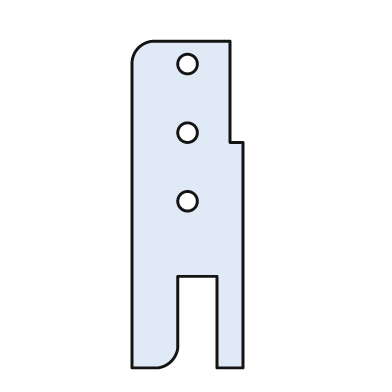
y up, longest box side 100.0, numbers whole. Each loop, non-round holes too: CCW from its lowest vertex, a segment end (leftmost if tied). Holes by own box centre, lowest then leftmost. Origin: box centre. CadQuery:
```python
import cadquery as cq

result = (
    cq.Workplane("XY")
    .moveTo(-17.0, -50.0)
    .lineTo(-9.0, -50.0)
    .threePointArc((-5.0, -48.0), (-3.0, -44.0))
    .lineTo(-3.0, -22.0)
    .lineTo(9.0, -22.0)
    .lineTo(9.0, -50.0)
    .lineTo(17.0, -50.0)
    .lineTo(17.0, 19.0)
    .lineTo(13.0, 19.0)
    .lineTo(13.0, 50.0)
    .lineTo(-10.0, 50.0)
    .threePointArc((-15.0, 48.0), (-17.0, 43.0))
    .close()
    .moveTo(0.0, 1.0)
    .circle(3.0)
    .moveTo(0.0, 22.0)
    .circle(3.0)
    .moveTo(0.0, 43.0)
    .circle(3.0)
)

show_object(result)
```